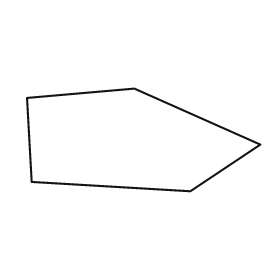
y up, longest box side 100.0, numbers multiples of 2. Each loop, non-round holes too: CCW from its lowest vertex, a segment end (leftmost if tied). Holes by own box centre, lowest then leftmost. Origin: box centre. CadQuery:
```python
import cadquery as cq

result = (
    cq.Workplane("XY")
    .moveTo(20.0, -22.0)
    .lineTo(50.0, -2.0)
    .lineTo(-4.0, 22.0)
    .lineTo(-50.0, 18.0)
    .lineTo(-48.0, -18.0)
    .close()
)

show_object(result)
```